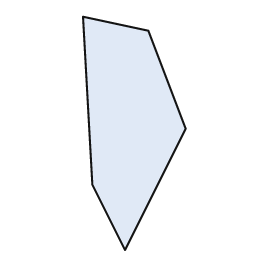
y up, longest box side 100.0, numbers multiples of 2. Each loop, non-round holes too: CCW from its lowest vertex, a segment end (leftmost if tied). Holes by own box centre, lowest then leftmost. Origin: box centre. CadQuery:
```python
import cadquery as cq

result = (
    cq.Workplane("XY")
    .moveTo(-4.0, -50.0)
    .lineTo(22.0, 2.0)
    .lineTo(6.0, 44.0)
    .lineTo(-22.0, 50.0)
    .lineTo(-18.0, -22.0)
    .close()
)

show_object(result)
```